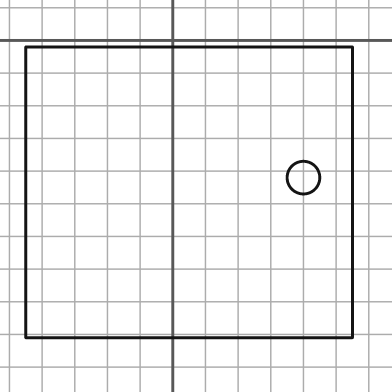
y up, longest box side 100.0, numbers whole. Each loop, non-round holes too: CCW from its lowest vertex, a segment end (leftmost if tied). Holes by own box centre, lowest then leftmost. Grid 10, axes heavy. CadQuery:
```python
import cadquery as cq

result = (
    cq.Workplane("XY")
    .moveTo(-45.0, -91.0)
    .lineTo(55.0, -91.0)
    .lineTo(55.0, -2.0)
    .lineTo(-45.0, -2.0)
    .close()
    .moveTo(40.0, -42.0)
    .circle(5.0)
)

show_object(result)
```